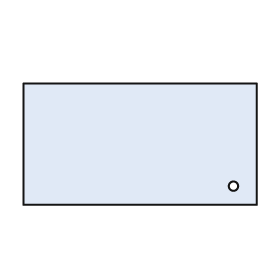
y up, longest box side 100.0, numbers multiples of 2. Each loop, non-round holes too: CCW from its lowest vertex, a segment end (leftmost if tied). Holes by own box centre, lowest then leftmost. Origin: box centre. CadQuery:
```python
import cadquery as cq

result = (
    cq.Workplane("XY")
    .moveTo(-50.0, -26.0)
    .lineTo(50.0, -26.0)
    .lineTo(50.0, 26.0)
    .lineTo(-50.0, 26.0)
    .close()
    .moveTo(40.0, -18.0)
    .circle(2.0)
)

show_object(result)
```